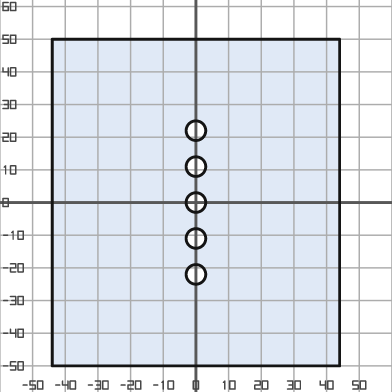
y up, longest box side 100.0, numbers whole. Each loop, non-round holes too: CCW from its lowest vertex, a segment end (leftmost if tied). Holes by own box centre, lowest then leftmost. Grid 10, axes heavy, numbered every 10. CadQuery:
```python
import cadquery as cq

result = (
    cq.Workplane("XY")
    .moveTo(-44.0, -50.0)
    .lineTo(44.0, -50.0)
    .lineTo(44.0, 50.0)
    .lineTo(-44.0, 50.0)
    .close()
    .moveTo(0.0, -22.0)
    .circle(3.0)
    .moveTo(0.0, -11.0)
    .circle(3.0)
    .moveTo(0.0, 0.0)
    .circle(3.0)
    .moveTo(0.0, 11.0)
    .circle(3.0)
    .moveTo(0.0, 22.0)
    .circle(3.0)
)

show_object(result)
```